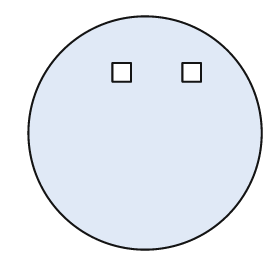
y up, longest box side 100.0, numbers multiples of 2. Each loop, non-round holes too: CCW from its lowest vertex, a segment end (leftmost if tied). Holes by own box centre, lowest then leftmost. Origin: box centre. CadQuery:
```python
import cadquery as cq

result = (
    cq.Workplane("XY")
    .moveTo(0.0, 0.0)
    .circle(50.0)
    .moveTo(-14.0, 22.0)
    .lineTo(-6.0, 22.0)
    .lineTo(-6.0, 30.0)
    .lineTo(-14.0, 30.0)
    .close()
    .moveTo(16.0, 22.0)
    .lineTo(24.0, 22.0)
    .lineTo(24.0, 30.0)
    .lineTo(16.0, 30.0)
    .close()
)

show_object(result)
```